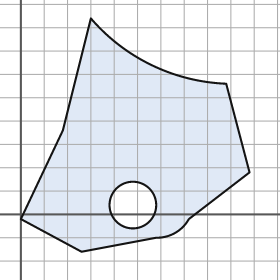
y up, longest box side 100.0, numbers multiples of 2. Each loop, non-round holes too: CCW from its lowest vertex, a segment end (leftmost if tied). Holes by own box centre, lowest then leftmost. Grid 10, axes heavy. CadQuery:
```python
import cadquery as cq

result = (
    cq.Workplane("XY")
    .moveTo(26.0, -16.0)
    .lineTo(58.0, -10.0)
    .threePointArc((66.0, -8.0), (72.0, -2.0))
    .lineTo(98.0, 18.0)
    .lineTo(88.0, 56.0)
    .threePointArc((56.0, 64.0), (30.0, 84.0))
    .lineTo(18.0, 36.0)
    .lineTo(0.0, -2.0)
    .close()
    .moveTo(48.0, 4.0)
    .circle(10.0)
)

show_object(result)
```